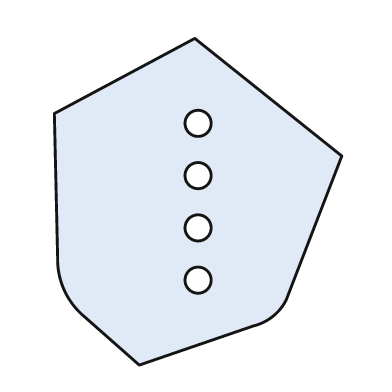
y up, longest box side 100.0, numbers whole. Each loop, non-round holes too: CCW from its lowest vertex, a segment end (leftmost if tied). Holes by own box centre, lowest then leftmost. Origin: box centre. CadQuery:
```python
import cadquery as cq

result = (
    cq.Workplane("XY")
    .moveTo(-18.0, -50.0)
    .lineTo(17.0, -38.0)
    .threePointArc((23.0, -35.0), (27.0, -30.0))
    .lineTo(44.0, 14.0)
    .lineTo(-1.0, 50.0)
    .lineTo(-44.0, 27.0)
    .lineTo(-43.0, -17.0)
    .threePointArc((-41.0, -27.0), (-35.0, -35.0))
    .close()
    .moveTo(0.0, -24.0)
    .circle(4.0)
    .moveTo(0.0, -8.0)
    .circle(4.0)
    .moveTo(0.0, 8.0)
    .circle(4.0)
    .moveTo(0.0, 24.0)
    .circle(4.0)
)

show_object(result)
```